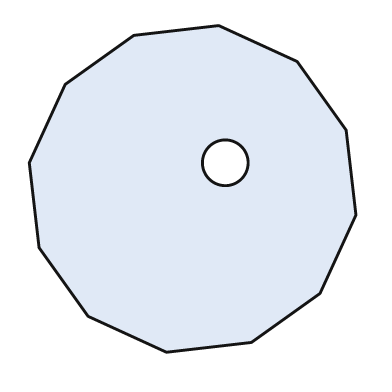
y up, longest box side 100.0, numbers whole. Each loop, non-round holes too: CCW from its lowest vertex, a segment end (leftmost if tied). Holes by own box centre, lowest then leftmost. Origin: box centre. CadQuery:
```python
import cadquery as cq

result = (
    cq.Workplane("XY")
    .moveTo(-8.0, -50.0)
    .lineTo(18.0, -47.0)
    .lineTo(39.0, -32.0)
    .lineTo(50.0, -8.0)
    .lineTo(47.0, 18.0)
    .lineTo(32.0, 39.0)
    .lineTo(8.0, 50.0)
    .lineTo(-18.0, 47.0)
    .lineTo(-39.0, 32.0)
    .lineTo(-50.0, 8.0)
    .lineTo(-47.0, -18.0)
    .lineTo(-32.0, -39.0)
    .close()
    .moveTo(10.0, 8.0)
    .circle(7.0)
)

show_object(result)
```